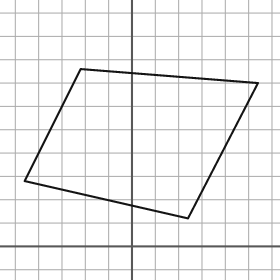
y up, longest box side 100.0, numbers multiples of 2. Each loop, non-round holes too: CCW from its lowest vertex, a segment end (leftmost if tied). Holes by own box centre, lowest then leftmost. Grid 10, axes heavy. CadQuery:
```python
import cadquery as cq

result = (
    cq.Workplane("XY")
    .moveTo(24.0, 12.0)
    .lineTo(54.0, 70.0)
    .lineTo(-22.0, 76.0)
    .lineTo(-46.0, 28.0)
    .close()
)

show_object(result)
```